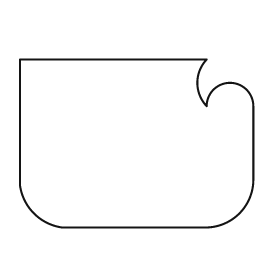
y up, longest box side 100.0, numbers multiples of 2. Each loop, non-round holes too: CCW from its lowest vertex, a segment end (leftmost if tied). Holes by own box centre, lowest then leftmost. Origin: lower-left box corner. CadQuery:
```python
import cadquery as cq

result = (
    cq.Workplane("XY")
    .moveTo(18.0, 0.0)
    .lineTo(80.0, 0.0)
    .threePointArc((94.0, 6.0), (100.0, 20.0))
    .lineTo(100.0, 52.0)
    .threePointArc((90.0, 62.0), (80.0, 52.0))
    .threePointArc((76.0, 62.0), (80.0, 72.0))
    .lineTo(0.0, 72.0)
    .lineTo(0.0, 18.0)
    .threePointArc((6.0, 6.0), (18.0, 0.0))
    .close()
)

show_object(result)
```